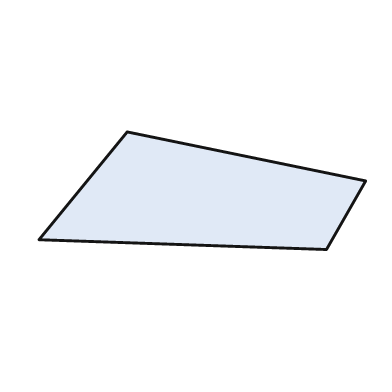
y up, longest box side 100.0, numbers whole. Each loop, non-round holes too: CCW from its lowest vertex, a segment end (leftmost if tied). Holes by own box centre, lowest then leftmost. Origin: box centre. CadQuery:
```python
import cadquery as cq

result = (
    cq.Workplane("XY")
    .moveTo(38.0, -18.0)
    .lineTo(50.0, 3.0)
    .lineTo(-23.0, 18.0)
    .lineTo(-50.0, -15.0)
    .close()
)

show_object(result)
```